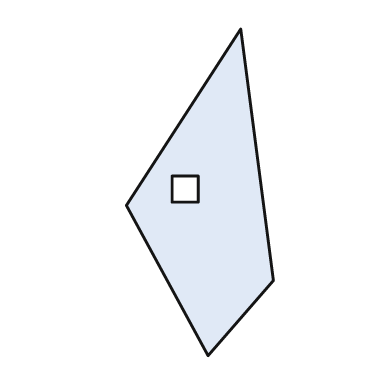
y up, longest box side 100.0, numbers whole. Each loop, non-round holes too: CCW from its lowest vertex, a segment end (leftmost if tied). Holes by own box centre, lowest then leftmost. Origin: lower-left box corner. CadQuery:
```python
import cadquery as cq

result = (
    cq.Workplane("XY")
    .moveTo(25.0, 0.0)
    .lineTo(45.0, 23.0)
    .lineTo(35.0, 100.0)
    .lineTo(0.0, 46.0)
    .close()
    .moveTo(14.0, 47.0)
    .lineTo(22.0, 47.0)
    .lineTo(22.0, 55.0)
    .lineTo(14.0, 55.0)
    .close()
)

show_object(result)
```